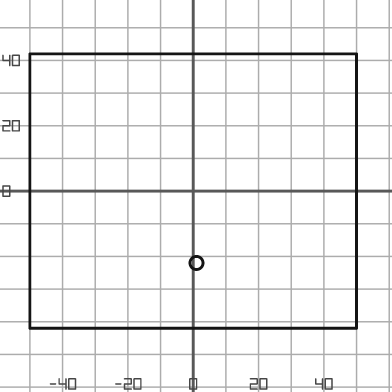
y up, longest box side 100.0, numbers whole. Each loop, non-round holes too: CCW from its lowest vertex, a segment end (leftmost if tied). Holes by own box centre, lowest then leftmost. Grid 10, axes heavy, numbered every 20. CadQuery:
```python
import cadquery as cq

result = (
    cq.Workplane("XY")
    .moveTo(-50.0, -42.0)
    .lineTo(50.0, -42.0)
    .lineTo(50.0, 42.0)
    .lineTo(-50.0, 42.0)
    .close()
    .moveTo(1.0, -22.0)
    .circle(2.0)
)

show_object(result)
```